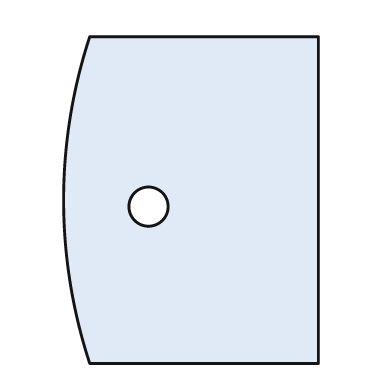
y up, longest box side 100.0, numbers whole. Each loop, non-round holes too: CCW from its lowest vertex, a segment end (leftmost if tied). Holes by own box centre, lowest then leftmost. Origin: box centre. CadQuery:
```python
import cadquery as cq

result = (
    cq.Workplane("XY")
    .moveTo(-31.0, -50.0)
    .lineTo(39.0, -50.0)
    .lineTo(39.0, 50.0)
    .lineTo(-31.0, 50.0)
    .threePointArc((-39.0, 0.0), (-31.0, -50.0))
    .close()
    .moveTo(-13.0, -2.0)
    .circle(6.0)
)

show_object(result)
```